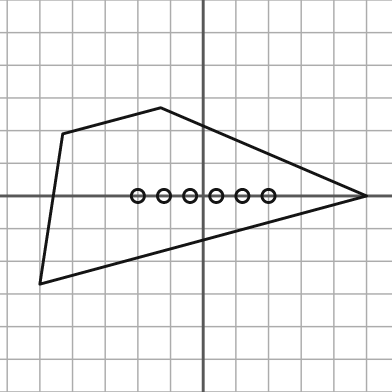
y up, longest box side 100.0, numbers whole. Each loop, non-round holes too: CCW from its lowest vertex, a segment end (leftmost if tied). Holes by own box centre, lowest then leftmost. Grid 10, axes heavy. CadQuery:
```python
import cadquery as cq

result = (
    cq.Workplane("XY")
    .moveTo(-50.0, -27.0)
    .lineTo(50.0, 0.0)
    .lineTo(-13.0, 27.0)
    .lineTo(-43.0, 19.0)
    .close()
    .moveTo(-20.0, 0.0)
    .circle(2.0)
    .moveTo(-12.0, 0.0)
    .circle(2.0)
    .moveTo(-4.0, 0.0)
    .circle(2.0)
    .moveTo(4.0, 0.0)
    .circle(2.0)
    .moveTo(12.0, 0.0)
    .circle(2.0)
    .moveTo(20.0, 0.0)
    .circle(2.0)
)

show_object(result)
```